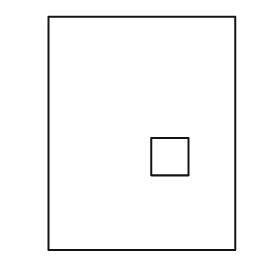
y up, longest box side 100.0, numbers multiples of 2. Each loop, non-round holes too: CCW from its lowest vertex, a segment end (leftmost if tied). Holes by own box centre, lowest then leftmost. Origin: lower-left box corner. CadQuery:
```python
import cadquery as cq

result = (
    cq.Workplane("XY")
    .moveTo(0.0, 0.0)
    .lineTo(80.0, 0.0)
    .lineTo(80.0, 100.0)
    .lineTo(0.0, 100.0)
    .close()
    .moveTo(44.0, 32.0)
    .lineTo(60.0, 32.0)
    .lineTo(60.0, 48.0)
    .lineTo(44.0, 48.0)
    .close()
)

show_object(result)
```